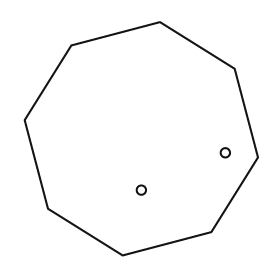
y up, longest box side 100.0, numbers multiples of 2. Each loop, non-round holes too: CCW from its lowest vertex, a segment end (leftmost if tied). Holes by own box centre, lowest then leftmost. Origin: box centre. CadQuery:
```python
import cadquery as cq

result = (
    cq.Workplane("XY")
    .moveTo(-8.0, -50.0)
    .lineTo(30.0, -40.0)
    .lineTo(50.0, -8.0)
    .lineTo(40.0, 30.0)
    .lineTo(8.0, 50.0)
    .lineTo(-30.0, 40.0)
    .lineTo(-50.0, 8.0)
    .lineTo(-40.0, -30.0)
    .close()
    .moveTo(0.0, -22.0)
    .circle(2.0)
    .moveTo(36.0, -6.0)
    .circle(2.0)
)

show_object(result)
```